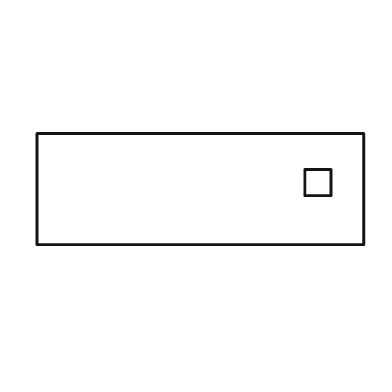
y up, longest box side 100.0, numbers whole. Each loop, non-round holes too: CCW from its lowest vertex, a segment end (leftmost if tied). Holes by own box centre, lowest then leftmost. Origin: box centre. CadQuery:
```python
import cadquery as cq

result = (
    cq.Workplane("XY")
    .moveTo(-50.0, -17.0)
    .lineTo(50.0, -17.0)
    .lineTo(50.0, 17.0)
    .lineTo(-50.0, 17.0)
    .close()
    .moveTo(32.0, -2.0)
    .lineTo(40.0, -2.0)
    .lineTo(40.0, 6.0)
    .lineTo(32.0, 6.0)
    .close()
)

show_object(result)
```